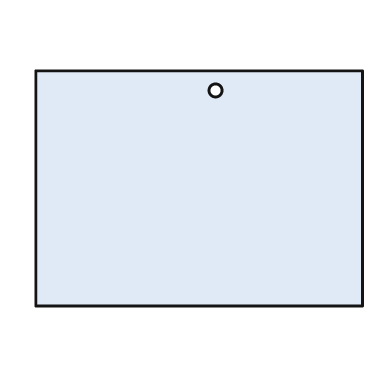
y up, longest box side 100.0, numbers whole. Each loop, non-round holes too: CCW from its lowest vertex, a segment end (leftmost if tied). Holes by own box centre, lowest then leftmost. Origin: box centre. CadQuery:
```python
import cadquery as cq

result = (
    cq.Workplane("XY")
    .moveTo(-50.0, -36.0)
    .lineTo(50.0, -36.0)
    .lineTo(50.0, 36.0)
    .lineTo(-50.0, 36.0)
    .close()
    .moveTo(5.0, 30.0)
    .circle(2.0)
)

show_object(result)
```